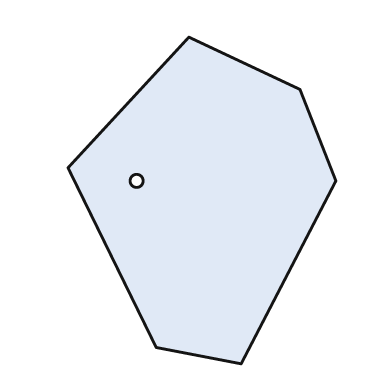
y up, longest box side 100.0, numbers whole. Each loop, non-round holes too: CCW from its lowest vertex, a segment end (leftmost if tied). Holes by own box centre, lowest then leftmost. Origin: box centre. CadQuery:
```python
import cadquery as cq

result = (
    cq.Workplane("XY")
    .moveTo(12.0, -50.0)
    .lineTo(41.0, 6.0)
    .lineTo(30.0, 34.0)
    .lineTo(-4.0, 50.0)
    .lineTo(-41.0, 10.0)
    .lineTo(-14.0, -45.0)
    .close()
    .moveTo(-20.0, 6.0)
    .circle(2.0)
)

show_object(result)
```